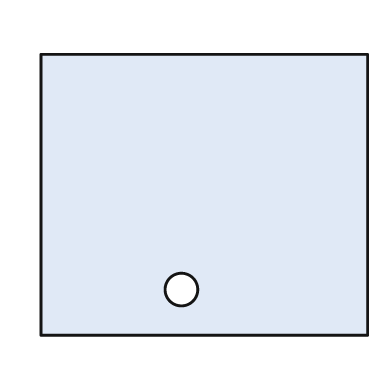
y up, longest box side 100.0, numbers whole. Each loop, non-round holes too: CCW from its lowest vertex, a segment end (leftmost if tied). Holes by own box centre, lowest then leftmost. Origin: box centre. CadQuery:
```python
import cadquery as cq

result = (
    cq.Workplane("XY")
    .moveTo(-50.0, -43.0)
    .lineTo(50.0, -43.0)
    .lineTo(50.0, 43.0)
    .lineTo(-50.0, 43.0)
    .close()
    .moveTo(-7.0, -29.0)
    .circle(5.0)
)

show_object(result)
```